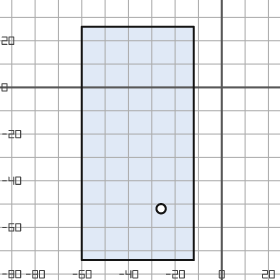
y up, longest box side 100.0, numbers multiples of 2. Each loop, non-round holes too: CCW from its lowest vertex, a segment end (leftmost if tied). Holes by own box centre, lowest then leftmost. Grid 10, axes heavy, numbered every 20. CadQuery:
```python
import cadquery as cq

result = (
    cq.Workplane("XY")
    .moveTo(-60.0, -74.0)
    .lineTo(-12.0, -74.0)
    .lineTo(-12.0, 26.0)
    .lineTo(-60.0, 26.0)
    .close()
    .moveTo(-26.0, -52.0)
    .circle(2.0)
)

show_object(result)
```